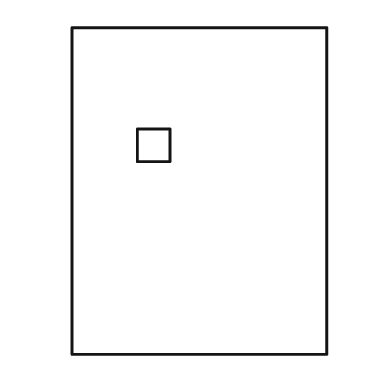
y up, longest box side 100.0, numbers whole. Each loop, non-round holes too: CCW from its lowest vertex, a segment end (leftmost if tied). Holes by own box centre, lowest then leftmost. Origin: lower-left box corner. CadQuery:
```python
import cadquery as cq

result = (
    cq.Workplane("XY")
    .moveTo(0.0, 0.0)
    .lineTo(78.0, 0.0)
    .lineTo(78.0, 100.0)
    .lineTo(0.0, 100.0)
    .close()
    .moveTo(20.0, 59.0)
    .lineTo(30.0, 59.0)
    .lineTo(30.0, 69.0)
    .lineTo(20.0, 69.0)
    .close()
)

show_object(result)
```